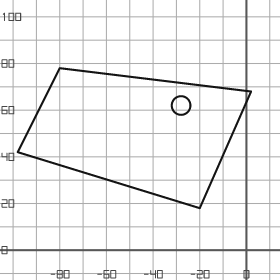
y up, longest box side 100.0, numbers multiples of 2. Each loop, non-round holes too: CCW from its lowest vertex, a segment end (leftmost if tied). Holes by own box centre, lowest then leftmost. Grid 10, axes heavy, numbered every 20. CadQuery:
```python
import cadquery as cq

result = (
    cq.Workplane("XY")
    .moveTo(-20.0, 18.0)
    .lineTo(2.0, 68.0)
    .lineTo(-80.0, 78.0)
    .lineTo(-98.0, 42.0)
    .close()
    .moveTo(-28.0, 62.0)
    .circle(4.0)
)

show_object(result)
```